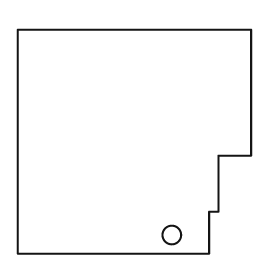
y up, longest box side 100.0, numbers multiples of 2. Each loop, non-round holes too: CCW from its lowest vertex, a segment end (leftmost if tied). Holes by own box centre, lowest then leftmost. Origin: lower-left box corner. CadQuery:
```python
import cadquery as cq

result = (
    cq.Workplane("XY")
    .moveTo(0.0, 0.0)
    .lineTo(82.0, 0.0)
    .lineTo(82.0, 18.0)
    .lineTo(86.0, 18.0)
    .lineTo(86.0, 42.0)
    .lineTo(100.0, 42.0)
    .lineTo(100.0, 96.0)
    .lineTo(0.0, 96.0)
    .close()
    .moveTo(66.0, 8.0)
    .circle(4.0)
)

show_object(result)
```